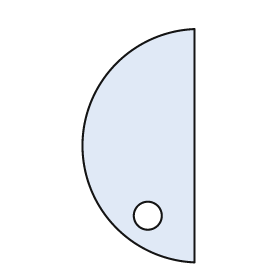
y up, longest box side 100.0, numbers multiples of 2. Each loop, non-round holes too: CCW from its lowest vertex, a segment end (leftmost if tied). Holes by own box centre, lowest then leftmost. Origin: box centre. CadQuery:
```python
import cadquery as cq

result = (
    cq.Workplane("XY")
    .moveTo(24.0, -50.0)
    .lineTo(24.0, 50.0)
    .threePointArc((-24.0, 0.0), (24.0, -50.0))
    .close()
    .moveTo(4.0, -30.0)
    .circle(6.0)
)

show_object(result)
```